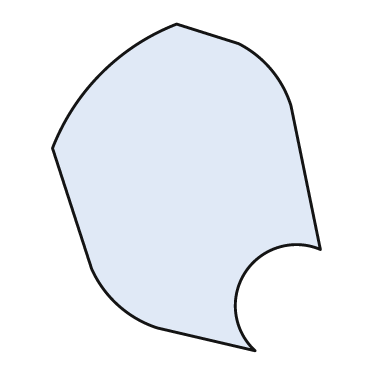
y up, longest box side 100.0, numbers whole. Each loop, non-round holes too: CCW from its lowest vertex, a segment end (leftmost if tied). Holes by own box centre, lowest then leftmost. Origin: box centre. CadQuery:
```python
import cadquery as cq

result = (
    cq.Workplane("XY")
    .moveTo(21.0, -50.0)
    .threePointArc((18.0, -26.0), (41.0, -19.0))
    .lineTo(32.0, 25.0)
    .threePointArc((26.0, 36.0), (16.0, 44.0))
    .lineTo(-3.0, 50.0)
    .threePointArc((-26.0, 35.0), (-41.0, 12.0))
    .lineTo(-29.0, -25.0)
    .threePointArc((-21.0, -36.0), (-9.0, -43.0))
    .close()
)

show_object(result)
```